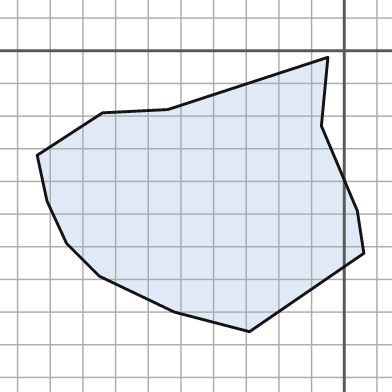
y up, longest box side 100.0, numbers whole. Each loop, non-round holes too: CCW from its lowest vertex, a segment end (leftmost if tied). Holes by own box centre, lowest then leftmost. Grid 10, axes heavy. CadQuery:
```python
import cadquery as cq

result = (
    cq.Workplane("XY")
    .moveTo(-29.0, -86.0)
    .lineTo(6.0, -62.0)
    .lineTo(4.0, -49.0)
    .lineTo(-7.0, -23.0)
    .lineTo(-5.0, -2.0)
    .lineTo(-54.0, -18.0)
    .lineTo(-74.0, -19.0)
    .lineTo(-94.0, -32.0)
    .lineTo(-91.0, -46.0)
    .lineTo(-85.0, -59.0)
    .lineTo(-75.0, -69.0)
    .lineTo(-52.0, -80.0)
    .close()
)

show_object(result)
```